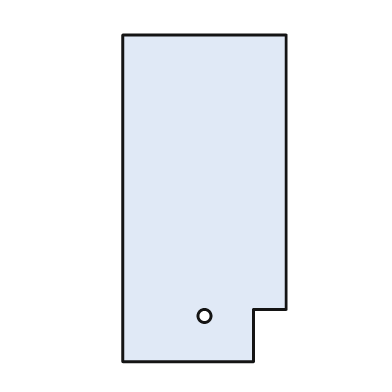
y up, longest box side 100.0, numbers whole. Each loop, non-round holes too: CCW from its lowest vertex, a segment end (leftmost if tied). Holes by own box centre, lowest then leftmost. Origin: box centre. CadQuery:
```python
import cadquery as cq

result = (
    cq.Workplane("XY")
    .moveTo(-25.0, -50.0)
    .lineTo(15.0, -50.0)
    .lineTo(15.0, -34.0)
    .lineTo(25.0, -34.0)
    .lineTo(25.0, 50.0)
    .lineTo(-25.0, 50.0)
    .close()
    .moveTo(0.0, -36.0)
    .circle(2.0)
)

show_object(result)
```